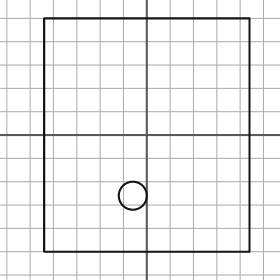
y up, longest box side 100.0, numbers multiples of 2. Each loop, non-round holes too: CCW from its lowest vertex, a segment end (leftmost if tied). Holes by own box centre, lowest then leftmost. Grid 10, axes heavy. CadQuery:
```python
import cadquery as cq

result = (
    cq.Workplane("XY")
    .moveTo(-44.0, -50.0)
    .lineTo(44.0, -50.0)
    .lineTo(44.0, 50.0)
    .lineTo(-44.0, 50.0)
    .close()
    .moveTo(-6.0, -26.0)
    .circle(6.0)
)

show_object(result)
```